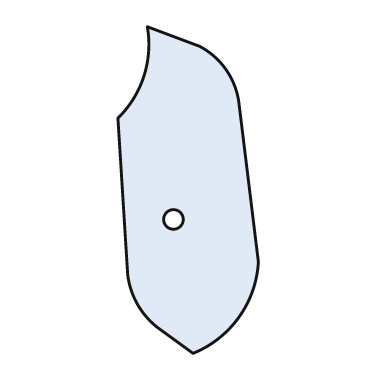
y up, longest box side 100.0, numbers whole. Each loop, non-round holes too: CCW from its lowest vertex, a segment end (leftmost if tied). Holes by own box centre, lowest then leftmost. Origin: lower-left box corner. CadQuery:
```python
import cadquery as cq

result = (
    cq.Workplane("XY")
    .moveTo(23.0, 0.0)
    .threePointArc((37.0, 11.0), (43.0, 28.0))
    .lineTo(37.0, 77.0)
    .threePointArc((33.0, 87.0), (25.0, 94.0))
    .lineTo(9.0, 100.0)
    .threePointArc((8.0, 85.0), (0.0, 72.0))
    .lineTo(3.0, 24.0)
    .threePointArc((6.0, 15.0), (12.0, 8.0))
    .close()
    .moveTo(17.0, 41.0)
    .circle(3.0)
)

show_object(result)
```